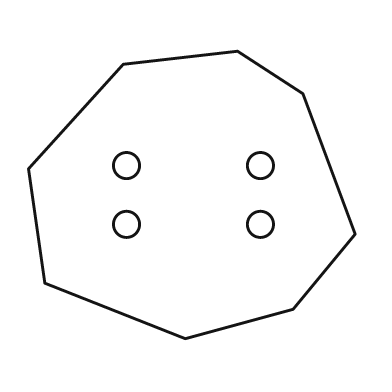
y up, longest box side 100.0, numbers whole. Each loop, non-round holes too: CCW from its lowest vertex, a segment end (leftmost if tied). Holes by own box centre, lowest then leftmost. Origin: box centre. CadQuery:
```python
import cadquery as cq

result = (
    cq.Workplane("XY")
    .moveTo(-2.0, -44.0)
    .lineTo(31.0, -35.0)
    .lineTo(50.0, -12.0)
    .lineTo(34.0, 31.0)
    .lineTo(14.0, 44.0)
    .lineTo(-21.0, 40.0)
    .lineTo(-50.0, 8.0)
    .lineTo(-45.0, -27.0)
    .close()
    .moveTo(-20.0, -9.0)
    .circle(4.0)
    .moveTo(21.0, -9.0)
    .circle(4.0)
    .moveTo(-20.0, 9.0)
    .circle(4.0)
    .moveTo(21.0, 9.0)
    .circle(4.0)
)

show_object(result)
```